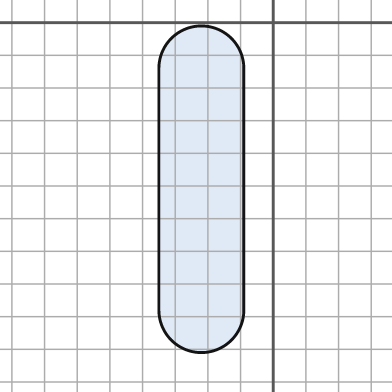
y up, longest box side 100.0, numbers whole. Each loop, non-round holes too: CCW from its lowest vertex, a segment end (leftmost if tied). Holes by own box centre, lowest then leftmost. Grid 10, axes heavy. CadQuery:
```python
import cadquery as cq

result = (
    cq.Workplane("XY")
    .moveTo(-35.0, -88.0)
    .threePointArc((-22.0, -101.0), (-9.0, -88.0))
    .lineTo(-9.0, -14.0)
    .threePointArc((-22.0, -1.0), (-35.0, -14.0))
    .close()
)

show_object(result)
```